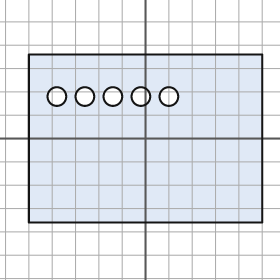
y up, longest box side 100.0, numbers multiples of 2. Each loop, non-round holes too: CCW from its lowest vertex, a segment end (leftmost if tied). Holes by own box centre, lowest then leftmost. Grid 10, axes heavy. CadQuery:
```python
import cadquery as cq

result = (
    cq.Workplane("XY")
    .moveTo(-50.0, -36.0)
    .lineTo(50.0, -36.0)
    .lineTo(50.0, 36.0)
    .lineTo(-50.0, 36.0)
    .close()
    .moveTo(-38.0, 18.0)
    .circle(4.0)
    .moveTo(-26.0, 18.0)
    .circle(4.0)
    .moveTo(-14.0, 18.0)
    .circle(4.0)
    .moveTo(-2.0, 18.0)
    .circle(4.0)
    .moveTo(10.0, 18.0)
    .circle(4.0)
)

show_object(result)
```